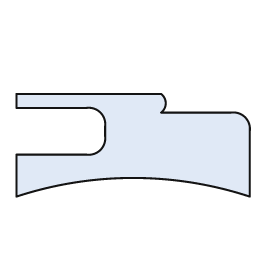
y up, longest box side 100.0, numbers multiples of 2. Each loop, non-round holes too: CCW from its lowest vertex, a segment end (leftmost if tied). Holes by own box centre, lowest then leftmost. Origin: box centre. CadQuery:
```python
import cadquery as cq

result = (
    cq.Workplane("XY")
    .moveTo(-50.0, -22.0)
    .threePointArc((0.0, -14.0), (50.0, -22.0))
    .lineTo(50.0, 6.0)
    .threePointArc((48.0, 12.0), (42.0, 14.0))
    .lineTo(12.0, 14.0)
    .threePointArc((14.0, 18.0), (12.0, 22.0))
    .lineTo(-50.0, 22.0)
    .lineTo(-50.0, 16.0)
    .lineTo(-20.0, 16.0)
    .threePointArc((-14.0, 14.0), (-12.0, 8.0))
    .lineTo(-12.0, 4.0)
    .threePointArc((-14.0, -2.0), (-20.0, -4.0))
    .lineTo(-50.0, -4.0)
    .close()
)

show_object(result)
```